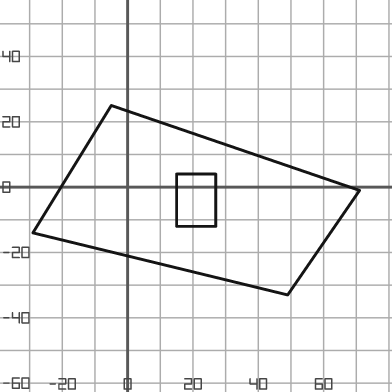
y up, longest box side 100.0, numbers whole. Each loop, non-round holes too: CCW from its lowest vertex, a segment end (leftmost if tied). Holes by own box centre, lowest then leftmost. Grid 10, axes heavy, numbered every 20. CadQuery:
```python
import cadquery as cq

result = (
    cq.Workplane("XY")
    .moveTo(49.0, -33.0)
    .lineTo(71.0, -1.0)
    .lineTo(-5.0, 25.0)
    .lineTo(-29.0, -14.0)
    .close()
    .moveTo(15.0, -12.0)
    .lineTo(27.0, -12.0)
    .lineTo(27.0, 4.0)
    .lineTo(15.0, 4.0)
    .close()
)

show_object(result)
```